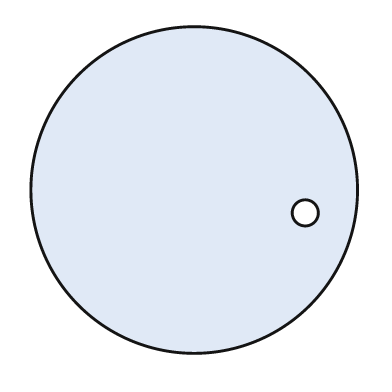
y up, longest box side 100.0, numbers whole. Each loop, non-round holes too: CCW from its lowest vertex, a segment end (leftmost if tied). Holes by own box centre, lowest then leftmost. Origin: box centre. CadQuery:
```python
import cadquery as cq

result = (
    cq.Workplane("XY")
    .moveTo(0.0, 0.0)
    .circle(50.0)
    .moveTo(34.0, -7.0)
    .circle(4.0)
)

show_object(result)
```